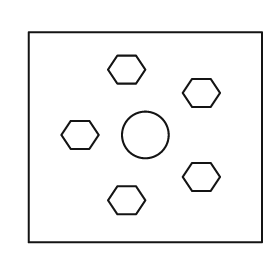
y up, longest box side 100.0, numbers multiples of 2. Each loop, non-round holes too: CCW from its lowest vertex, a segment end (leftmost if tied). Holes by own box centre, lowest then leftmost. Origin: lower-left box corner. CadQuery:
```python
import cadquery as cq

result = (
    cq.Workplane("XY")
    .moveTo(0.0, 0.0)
    .lineTo(100.0, 0.0)
    .lineTo(100.0, 90.0)
    .lineTo(0.0, 90.0)
    .close()
    .moveTo(38.0, 12.0)
    .lineTo(46.0, 12.0)
    .lineTo(50.0, 18.0)
    .lineTo(46.0, 24.0)
    .lineTo(38.0, 24.0)
    .lineTo(34.0, 18.0)
    .close()
    .moveTo(70.0, 22.0)
    .lineTo(78.0, 22.0)
    .lineTo(82.0, 28.0)
    .lineTo(78.0, 34.0)
    .lineTo(70.0, 34.0)
    .lineTo(66.0, 28.0)
    .close()
    .moveTo(18.0, 40.0)
    .lineTo(26.0, 40.0)
    .lineTo(30.0, 46.0)
    .lineTo(26.0, 52.0)
    .lineTo(18.0, 52.0)
    .lineTo(14.0, 46.0)
    .close()
    .moveTo(50.0, 46.0)
    .circle(10.0)
    .moveTo(70.0, 58.0)
    .lineTo(78.0, 58.0)
    .lineTo(82.0, 64.0)
    .lineTo(78.0, 70.0)
    .lineTo(70.0, 70.0)
    .lineTo(66.0, 64.0)
    .close()
    .moveTo(38.0, 68.0)
    .lineTo(46.0, 68.0)
    .lineTo(50.0, 74.0)
    .lineTo(46.0, 80.0)
    .lineTo(38.0, 80.0)
    .lineTo(34.0, 74.0)
    .close()
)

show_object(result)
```